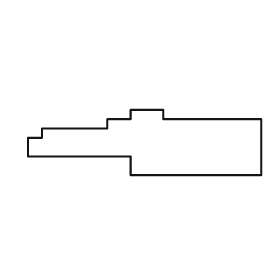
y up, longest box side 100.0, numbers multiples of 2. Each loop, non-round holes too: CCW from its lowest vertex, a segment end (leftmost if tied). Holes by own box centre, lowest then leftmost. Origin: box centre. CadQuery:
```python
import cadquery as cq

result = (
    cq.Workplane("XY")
    .moveTo(-6.0, -14.0)
    .lineTo(50.0, -14.0)
    .lineTo(50.0, 10.0)
    .lineTo(8.0, 10.0)
    .lineTo(8.0, 14.0)
    .lineTo(-6.0, 14.0)
    .lineTo(-6.0, 10.0)
    .lineTo(-16.0, 10.0)
    .lineTo(-16.0, 6.0)
    .lineTo(-44.0, 6.0)
    .lineTo(-44.0, 2.0)
    .lineTo(-50.0, 2.0)
    .lineTo(-50.0, -6.0)
    .lineTo(-6.0, -6.0)
    .close()
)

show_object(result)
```